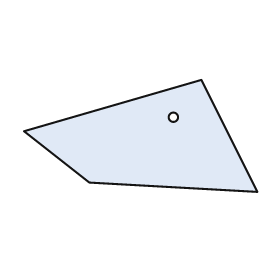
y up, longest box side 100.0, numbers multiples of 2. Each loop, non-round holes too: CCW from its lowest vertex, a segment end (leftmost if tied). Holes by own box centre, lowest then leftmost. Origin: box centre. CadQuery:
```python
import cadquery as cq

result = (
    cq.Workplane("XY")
    .moveTo(50.0, -24.0)
    .lineTo(26.0, 24.0)
    .lineTo(-50.0, 2.0)
    .lineTo(-22.0, -20.0)
    .close()
    .moveTo(14.0, 8.0)
    .circle(2.0)
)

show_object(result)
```